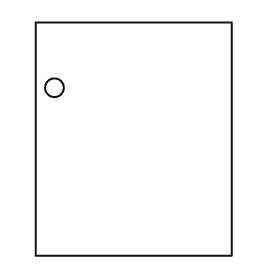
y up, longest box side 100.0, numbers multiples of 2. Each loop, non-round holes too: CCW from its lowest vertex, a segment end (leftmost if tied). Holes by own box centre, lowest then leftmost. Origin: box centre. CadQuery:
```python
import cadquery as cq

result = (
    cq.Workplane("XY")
    .moveTo(-42.0, -50.0)
    .lineTo(42.0, -50.0)
    .lineTo(42.0, 50.0)
    .lineTo(-42.0, 50.0)
    .close()
    .moveTo(-34.0, 22.0)
    .circle(4.0)
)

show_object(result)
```